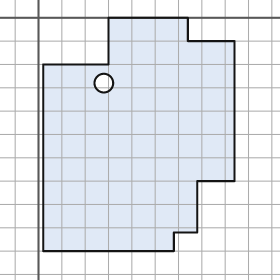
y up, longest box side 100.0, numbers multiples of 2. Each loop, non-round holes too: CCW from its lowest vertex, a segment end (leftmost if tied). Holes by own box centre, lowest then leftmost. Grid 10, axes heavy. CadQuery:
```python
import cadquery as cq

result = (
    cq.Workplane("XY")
    .moveTo(2.0, -100.0)
    .lineTo(58.0, -100.0)
    .lineTo(58.0, -92.0)
    .lineTo(68.0, -92.0)
    .lineTo(68.0, -70.0)
    .lineTo(84.0, -70.0)
    .lineTo(84.0, -10.0)
    .lineTo(64.0, -10.0)
    .lineTo(64.0, 0.0)
    .lineTo(30.0, 0.0)
    .lineTo(30.0, -20.0)
    .lineTo(2.0, -20.0)
    .close()
    .moveTo(28.0, -28.0)
    .circle(4.0)
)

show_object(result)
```